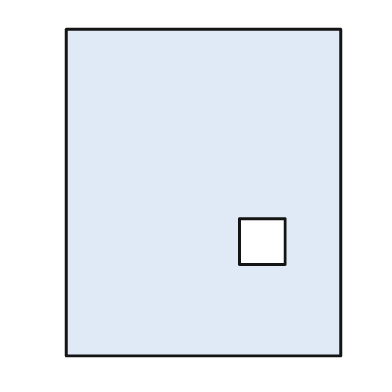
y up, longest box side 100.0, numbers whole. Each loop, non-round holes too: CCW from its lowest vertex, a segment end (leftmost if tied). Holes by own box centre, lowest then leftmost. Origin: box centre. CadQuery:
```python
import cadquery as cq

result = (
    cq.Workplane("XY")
    .moveTo(-42.0, -50.0)
    .lineTo(42.0, -50.0)
    .lineTo(42.0, 50.0)
    .lineTo(-42.0, 50.0)
    .close()
    .moveTo(11.0, -22.0)
    .lineTo(25.0, -22.0)
    .lineTo(25.0, -8.0)
    .lineTo(11.0, -8.0)
    .close()
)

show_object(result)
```